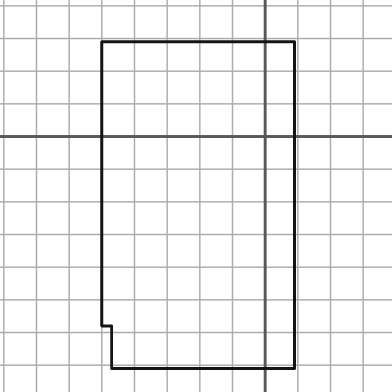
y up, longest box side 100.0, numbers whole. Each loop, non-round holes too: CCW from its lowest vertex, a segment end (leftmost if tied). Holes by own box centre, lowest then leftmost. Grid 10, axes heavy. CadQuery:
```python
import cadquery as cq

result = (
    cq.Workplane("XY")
    .moveTo(-47.0, -71.0)
    .lineTo(9.0, -71.0)
    .lineTo(9.0, 29.0)
    .lineTo(-50.0, 29.0)
    .lineTo(-50.0, -58.0)
    .lineTo(-47.0, -58.0)
    .close()
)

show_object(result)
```